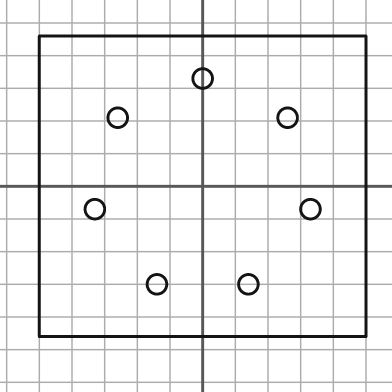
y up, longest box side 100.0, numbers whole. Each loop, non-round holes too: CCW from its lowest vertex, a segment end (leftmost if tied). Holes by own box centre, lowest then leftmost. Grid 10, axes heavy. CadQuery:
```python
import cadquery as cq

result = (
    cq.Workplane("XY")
    .moveTo(-50.0, -46.0)
    .lineTo(50.0, -46.0)
    .lineTo(50.0, 46.0)
    .lineTo(-50.0, 46.0)
    .close()
    .moveTo(-14.0, -30.0)
    .circle(3.0)
    .moveTo(14.0, -30.0)
    .circle(3.0)
    .moveTo(-33.0, -7.0)
    .circle(3.0)
    .moveTo(33.0, -7.0)
    .circle(3.0)
    .moveTo(-26.0, 21.0)
    .circle(3.0)
    .moveTo(26.0, 21.0)
    .circle(3.0)
    .moveTo(0.0, 33.0)
    .circle(3.0)
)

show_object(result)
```